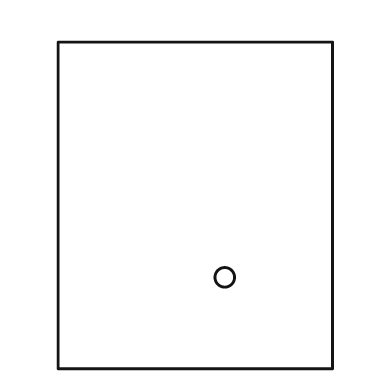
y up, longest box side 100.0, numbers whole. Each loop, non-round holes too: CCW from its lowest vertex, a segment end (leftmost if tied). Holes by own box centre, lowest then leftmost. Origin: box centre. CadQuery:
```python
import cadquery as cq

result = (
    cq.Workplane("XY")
    .moveTo(-42.0, -50.0)
    .lineTo(42.0, -50.0)
    .lineTo(42.0, 50.0)
    .lineTo(-42.0, 50.0)
    .close()
    .moveTo(9.0, -22.0)
    .circle(3.0)
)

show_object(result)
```